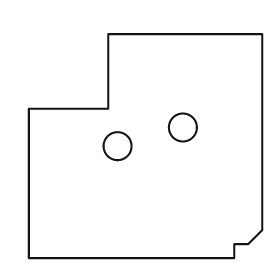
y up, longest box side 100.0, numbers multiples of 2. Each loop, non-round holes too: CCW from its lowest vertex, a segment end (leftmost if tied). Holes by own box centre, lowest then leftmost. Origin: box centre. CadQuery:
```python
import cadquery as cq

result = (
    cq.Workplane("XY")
    .moveTo(-50.0, -48.0)
    .lineTo(38.0, -48.0)
    .lineTo(38.0, -42.0)
    .lineTo(44.0, -42.0)
    .lineTo(50.0, -36.0)
    .lineTo(50.0, 48.0)
    .lineTo(-16.0, 48.0)
    .lineTo(-16.0, 16.0)
    .lineTo(-50.0, 16.0)
    .close()
    .moveTo(-12.0, 0.0)
    .circle(6.0)
    .moveTo(16.0, 8.0)
    .circle(6.0)
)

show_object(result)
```